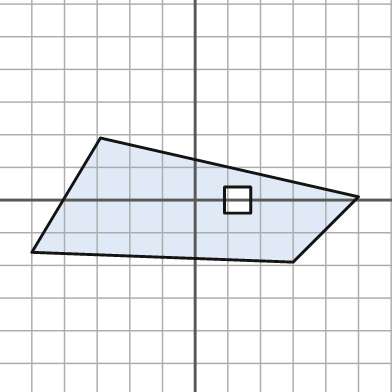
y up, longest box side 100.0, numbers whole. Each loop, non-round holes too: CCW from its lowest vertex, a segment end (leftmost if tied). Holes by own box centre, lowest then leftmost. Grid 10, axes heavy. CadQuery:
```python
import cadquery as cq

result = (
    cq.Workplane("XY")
    .moveTo(30.0, -19.0)
    .lineTo(50.0, 1.0)
    .lineTo(-29.0, 19.0)
    .lineTo(-50.0, -16.0)
    .close()
    .moveTo(9.0, -4.0)
    .lineTo(17.0, -4.0)
    .lineTo(17.0, 4.0)
    .lineTo(9.0, 4.0)
    .close()
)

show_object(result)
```